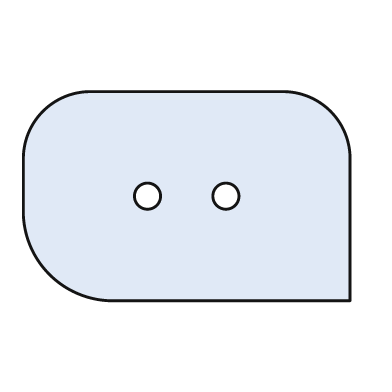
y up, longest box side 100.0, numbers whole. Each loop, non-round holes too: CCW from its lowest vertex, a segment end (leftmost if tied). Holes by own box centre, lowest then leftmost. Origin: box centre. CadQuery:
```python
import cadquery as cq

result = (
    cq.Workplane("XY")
    .moveTo(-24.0, -32.0)
    .lineTo(50.0, -32.0)
    .lineTo(50.0, 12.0)
    .threePointArc((44.0, 26.0), (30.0, 32.0))
    .lineTo(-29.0, 32.0)
    .threePointArc((-44.0, 26.0), (-50.0, 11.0))
    .lineTo(-50.0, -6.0)
    .threePointArc((-42.0, -24.0), (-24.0, -32.0))
    .close()
    .moveTo(-12.0, 0.0)
    .circle(4.0)
    .moveTo(12.0, 0.0)
    .circle(4.0)
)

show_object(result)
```